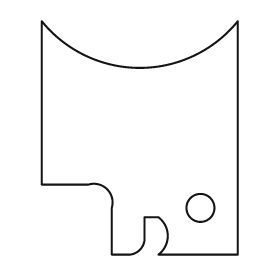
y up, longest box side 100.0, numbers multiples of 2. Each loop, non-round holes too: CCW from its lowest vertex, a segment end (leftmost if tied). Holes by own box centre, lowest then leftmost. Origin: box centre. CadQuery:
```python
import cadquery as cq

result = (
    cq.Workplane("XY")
    .moveTo(-12.0, -50.0)
    .lineTo(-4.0, -50.0)
    .threePointArc((0.0, -48.0), (2.0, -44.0))
    .lineTo(2.0, -34.0)
    .lineTo(8.0, -34.0)
    .threePointArc((12.0, -42.0), (8.0, -50.0))
    .lineTo(42.0, -50.0)
    .lineTo(42.0, 50.0)
    .threePointArc((0.0, 30.0), (-42.0, 50.0))
    .lineTo(-42.0, -20.0)
    .lineTo(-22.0, -20.0)
    .threePointArc((-14.0, -22.0), (-12.0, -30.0))
    .close()
    .moveTo(26.0, -30.0)
    .circle(6.0)
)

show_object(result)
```